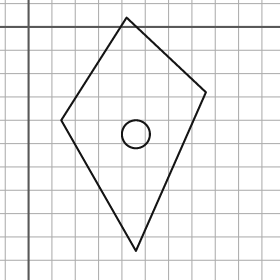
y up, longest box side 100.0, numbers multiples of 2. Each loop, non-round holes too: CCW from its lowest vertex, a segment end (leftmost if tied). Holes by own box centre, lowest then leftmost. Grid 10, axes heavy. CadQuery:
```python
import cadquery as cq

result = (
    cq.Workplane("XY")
    .moveTo(46.0, -96.0)
    .lineTo(76.0, -28.0)
    .lineTo(42.0, 4.0)
    .lineTo(14.0, -40.0)
    .close()
    .moveTo(46.0, -46.0)
    .circle(6.0)
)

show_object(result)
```